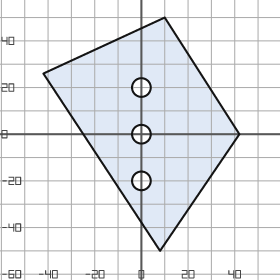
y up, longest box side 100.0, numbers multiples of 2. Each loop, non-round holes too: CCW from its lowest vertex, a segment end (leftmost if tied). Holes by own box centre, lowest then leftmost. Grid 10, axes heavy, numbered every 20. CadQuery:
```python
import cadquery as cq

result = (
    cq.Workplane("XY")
    .moveTo(8.0, -50.0)
    .lineTo(42.0, 0.0)
    .lineTo(10.0, 50.0)
    .lineTo(-42.0, 26.0)
    .close()
    .moveTo(0.0, -20.0)
    .circle(4.0)
    .moveTo(0.0, 0.0)
    .circle(4.0)
    .moveTo(0.0, 20.0)
    .circle(4.0)
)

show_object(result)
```